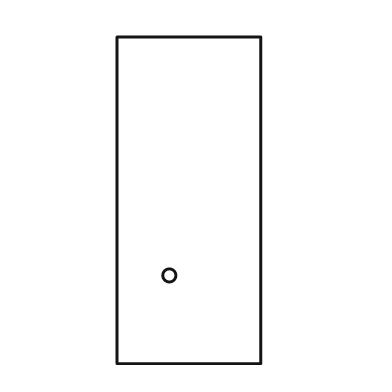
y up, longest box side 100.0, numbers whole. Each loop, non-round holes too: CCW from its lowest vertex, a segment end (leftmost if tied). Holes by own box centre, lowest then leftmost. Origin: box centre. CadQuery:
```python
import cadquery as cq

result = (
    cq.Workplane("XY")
    .moveTo(-22.0, -50.0)
    .lineTo(22.0, -50.0)
    .lineTo(22.0, 50.0)
    .lineTo(-22.0, 50.0)
    .close()
    .moveTo(-6.0, -23.0)
    .circle(2.0)
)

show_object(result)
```